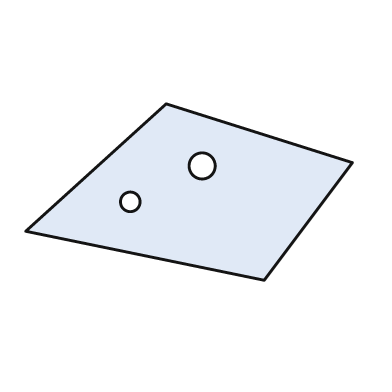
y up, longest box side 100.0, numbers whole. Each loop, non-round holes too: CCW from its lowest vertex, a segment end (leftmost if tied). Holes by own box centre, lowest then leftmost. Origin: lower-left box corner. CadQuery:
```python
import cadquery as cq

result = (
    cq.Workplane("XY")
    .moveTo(73.0, 0.0)
    .lineTo(100.0, 36.0)
    .lineTo(43.0, 54.0)
    .lineTo(0.0, 15.0)
    .close()
    .moveTo(32.0, 24.0)
    .circle(3.0)
    .moveTo(54.0, 35.0)
    .circle(4.0)
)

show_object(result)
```